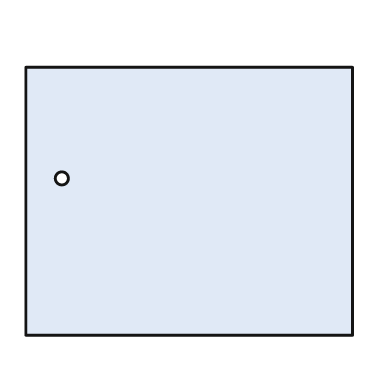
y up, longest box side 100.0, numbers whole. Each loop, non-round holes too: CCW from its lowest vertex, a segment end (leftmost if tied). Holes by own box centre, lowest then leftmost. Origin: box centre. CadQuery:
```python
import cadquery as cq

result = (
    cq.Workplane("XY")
    .moveTo(-50.0, -41.0)
    .lineTo(50.0, -41.0)
    .lineTo(50.0, 41.0)
    .lineTo(-50.0, 41.0)
    .close()
    .moveTo(-39.0, 7.0)
    .circle(2.0)
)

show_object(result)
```